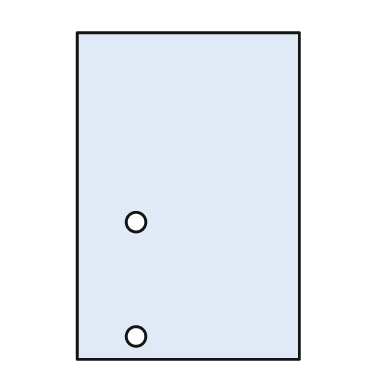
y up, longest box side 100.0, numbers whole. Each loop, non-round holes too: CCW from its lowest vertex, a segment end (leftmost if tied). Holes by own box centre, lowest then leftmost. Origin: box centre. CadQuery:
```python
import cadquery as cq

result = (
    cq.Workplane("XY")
    .moveTo(-34.0, -50.0)
    .lineTo(34.0, -50.0)
    .lineTo(34.0, 50.0)
    .lineTo(-34.0, 50.0)
    .close()
    .moveTo(-16.0, -43.0)
    .circle(3.0)
    .moveTo(-16.0, -8.0)
    .circle(3.0)
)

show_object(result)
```